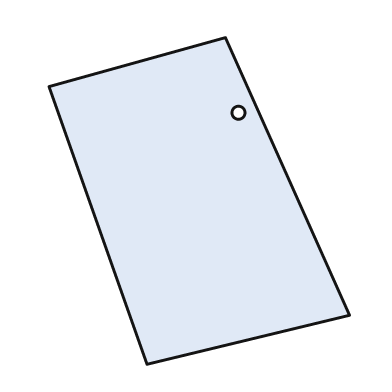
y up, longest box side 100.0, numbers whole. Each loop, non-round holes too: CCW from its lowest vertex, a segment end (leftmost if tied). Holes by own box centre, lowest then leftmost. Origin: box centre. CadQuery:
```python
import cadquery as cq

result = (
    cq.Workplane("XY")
    .moveTo(-16.0, -50.0)
    .lineTo(46.0, -35.0)
    .lineTo(8.0, 50.0)
    .lineTo(-46.0, 35.0)
    .close()
    .moveTo(12.0, 27.0)
    .circle(2.0)
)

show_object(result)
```